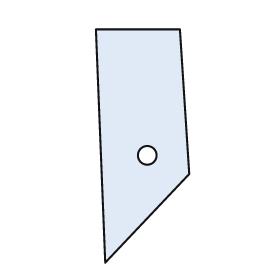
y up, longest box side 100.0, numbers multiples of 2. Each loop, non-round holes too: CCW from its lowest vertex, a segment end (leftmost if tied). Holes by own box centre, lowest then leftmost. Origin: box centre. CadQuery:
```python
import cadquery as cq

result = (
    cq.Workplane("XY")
    .moveTo(-16.0, -50.0)
    .lineTo(20.0, -12.0)
    .lineTo(16.0, 50.0)
    .lineTo(-20.0, 50.0)
    .close()
    .moveTo(2.0, -4.0)
    .circle(4.0)
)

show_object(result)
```